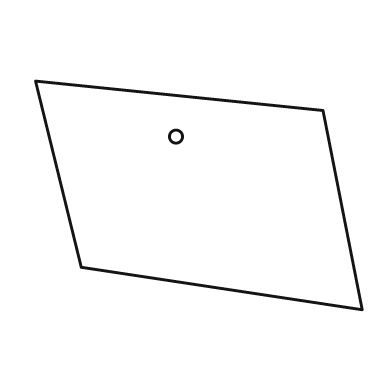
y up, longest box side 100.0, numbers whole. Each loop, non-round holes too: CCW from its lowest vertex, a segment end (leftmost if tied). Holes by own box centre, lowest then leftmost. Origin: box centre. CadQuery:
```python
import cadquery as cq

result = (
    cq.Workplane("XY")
    .moveTo(50.0, -35.0)
    .lineTo(38.0, 26.0)
    .lineTo(-50.0, 35.0)
    .lineTo(-36.0, -22.0)
    .close()
    .moveTo(-7.0, 18.0)
    .circle(2.0)
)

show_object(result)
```